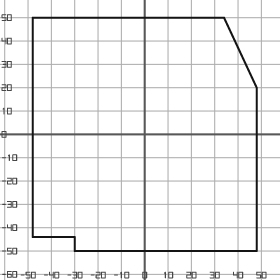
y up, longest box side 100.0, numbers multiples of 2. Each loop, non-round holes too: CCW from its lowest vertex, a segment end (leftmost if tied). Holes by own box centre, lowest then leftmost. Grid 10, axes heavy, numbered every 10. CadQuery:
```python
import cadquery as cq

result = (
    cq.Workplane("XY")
    .moveTo(-30.0, -50.0)
    .lineTo(48.0, -50.0)
    .lineTo(48.0, 20.0)
    .lineTo(34.0, 50.0)
    .lineTo(-48.0, 50.0)
    .lineTo(-48.0, -44.0)
    .lineTo(-30.0, -44.0)
    .close()
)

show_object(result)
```